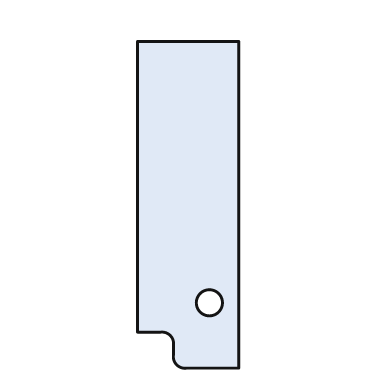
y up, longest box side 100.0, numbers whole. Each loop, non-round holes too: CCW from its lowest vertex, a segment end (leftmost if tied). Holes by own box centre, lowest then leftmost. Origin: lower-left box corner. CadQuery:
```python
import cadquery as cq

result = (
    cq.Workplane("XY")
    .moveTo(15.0, 0.0)
    .lineTo(31.0, 0.0)
    .lineTo(31.0, 100.0)
    .lineTo(0.0, 100.0)
    .lineTo(0.0, 11.0)
    .lineTo(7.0, 11.0)
    .threePointArc((10.0, 10.0), (11.0, 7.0))
    .lineTo(11.0, 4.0)
    .threePointArc((12.0, 1.0), (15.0, 0.0))
    .close()
    .moveTo(22.0, 20.0)
    .circle(4.0)
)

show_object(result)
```